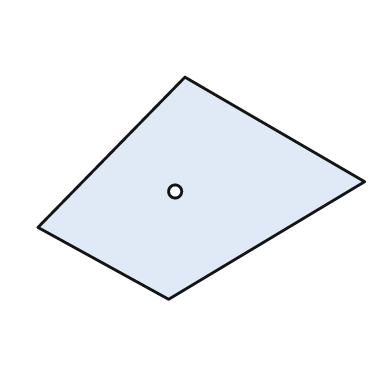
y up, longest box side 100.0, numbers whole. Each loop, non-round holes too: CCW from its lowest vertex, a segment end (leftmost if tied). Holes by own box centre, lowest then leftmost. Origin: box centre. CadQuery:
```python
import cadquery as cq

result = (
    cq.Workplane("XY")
    .moveTo(-10.0, -34.0)
    .lineTo(50.0, 2.0)
    .lineTo(-5.0, 34.0)
    .lineTo(-50.0, -12.0)
    .close()
    .moveTo(-8.0, -1.0)
    .circle(2.0)
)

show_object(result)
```